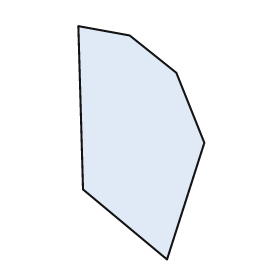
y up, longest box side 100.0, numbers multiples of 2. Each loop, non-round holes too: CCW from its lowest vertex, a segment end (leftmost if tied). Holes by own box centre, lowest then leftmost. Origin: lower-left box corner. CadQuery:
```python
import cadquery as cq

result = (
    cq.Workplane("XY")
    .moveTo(38.0, 0.0)
    .lineTo(54.0, 50.0)
    .lineTo(42.0, 80.0)
    .lineTo(22.0, 96.0)
    .lineTo(0.0, 100.0)
    .lineTo(2.0, 30.0)
    .close()
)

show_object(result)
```